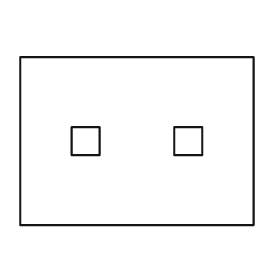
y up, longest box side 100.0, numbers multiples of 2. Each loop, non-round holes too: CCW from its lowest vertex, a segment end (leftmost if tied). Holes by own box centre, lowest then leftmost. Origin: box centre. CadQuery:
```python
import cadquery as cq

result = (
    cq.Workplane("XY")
    .moveTo(-50.0, -36.0)
    .lineTo(50.0, -36.0)
    .lineTo(50.0, 36.0)
    .lineTo(-50.0, 36.0)
    .close()
    .moveTo(-28.0, -6.0)
    .lineTo(-16.0, -6.0)
    .lineTo(-16.0, 6.0)
    .lineTo(-28.0, 6.0)
    .close()
    .moveTo(16.0, -6.0)
    .lineTo(28.0, -6.0)
    .lineTo(28.0, 6.0)
    .lineTo(16.0, 6.0)
    .close()
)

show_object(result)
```